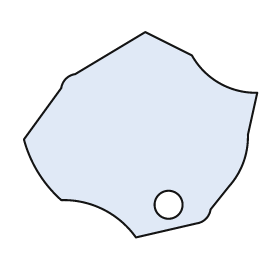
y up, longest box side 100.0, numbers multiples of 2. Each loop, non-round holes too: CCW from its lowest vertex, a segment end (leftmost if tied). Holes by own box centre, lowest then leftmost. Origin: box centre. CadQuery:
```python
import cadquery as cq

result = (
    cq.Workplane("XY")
    .moveTo(-2.0, -44.0)
    .lineTo(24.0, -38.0)
    .threePointArc((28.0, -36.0), (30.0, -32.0))
    .lineTo(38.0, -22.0)
    .threePointArc((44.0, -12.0), (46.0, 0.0))
    .lineTo(50.0, 18.0)
    .threePointArc((34.0, 22.0), (22.0, 34.0))
    .lineTo(2.0, 44.0)
    .lineTo(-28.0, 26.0)
    .threePointArc((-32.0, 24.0), (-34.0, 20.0))
    .lineTo(-50.0, -2.0)
    .threePointArc((-44.0, -16.0), (-34.0, -28.0))
    .threePointArc((-16.0, -32.0), (-2.0, -44.0))
    .close()
    .moveTo(12.0, -30.0)
    .circle(6.0)
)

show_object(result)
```